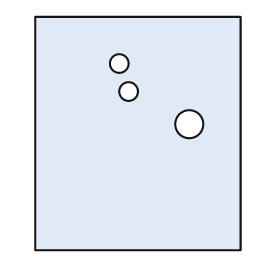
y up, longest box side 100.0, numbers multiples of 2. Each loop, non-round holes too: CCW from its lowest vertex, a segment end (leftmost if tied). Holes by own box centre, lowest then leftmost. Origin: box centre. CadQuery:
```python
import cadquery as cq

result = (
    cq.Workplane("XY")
    .moveTo(-44.0, -50.0)
    .lineTo(44.0, -50.0)
    .lineTo(44.0, 50.0)
    .lineTo(-44.0, 50.0)
    .close()
    .moveTo(22.0, 4.0)
    .circle(6.0)
    .moveTo(-4.0, 18.0)
    .circle(4.0)
    .moveTo(-8.0, 30.0)
    .circle(4.0)
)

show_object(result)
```